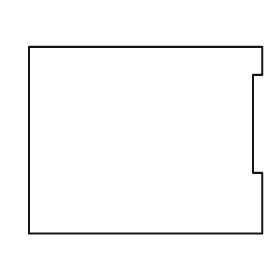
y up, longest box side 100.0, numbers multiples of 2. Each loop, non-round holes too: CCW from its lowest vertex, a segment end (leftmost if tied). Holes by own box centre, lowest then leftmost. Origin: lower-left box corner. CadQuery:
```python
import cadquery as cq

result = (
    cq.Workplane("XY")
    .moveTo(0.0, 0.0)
    .lineTo(100.0, 0.0)
    .lineTo(100.0, 26.0)
    .lineTo(96.0, 26.0)
    .lineTo(96.0, 68.0)
    .lineTo(100.0, 68.0)
    .lineTo(100.0, 80.0)
    .lineTo(0.0, 80.0)
    .close()
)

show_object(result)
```